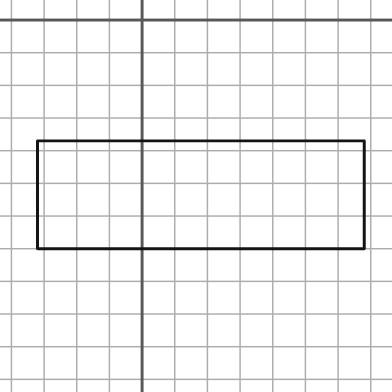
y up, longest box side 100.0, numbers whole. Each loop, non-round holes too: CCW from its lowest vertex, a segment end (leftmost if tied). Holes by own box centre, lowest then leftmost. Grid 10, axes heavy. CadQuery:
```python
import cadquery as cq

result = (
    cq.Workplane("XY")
    .moveTo(-32.0, -70.0)
    .lineTo(68.0, -70.0)
    .lineTo(68.0, -37.0)
    .lineTo(-32.0, -37.0)
    .close()
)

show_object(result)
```